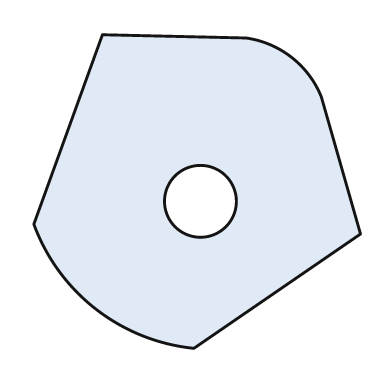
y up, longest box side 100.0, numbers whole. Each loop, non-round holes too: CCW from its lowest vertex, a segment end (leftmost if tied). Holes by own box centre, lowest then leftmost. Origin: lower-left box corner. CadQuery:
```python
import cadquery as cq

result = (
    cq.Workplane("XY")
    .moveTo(49.0, 0.0)
    .lineTo(100.0, 35.0)
    .lineTo(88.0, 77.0)
    .threePointArc((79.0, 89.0), (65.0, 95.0))
    .lineTo(21.0, 96.0)
    .lineTo(0.0, 38.0)
    .threePointArc((19.0, 12.0), (49.0, 0.0))
    .close()
    .moveTo(51.0, 45.0)
    .circle(11.0)
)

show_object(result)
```